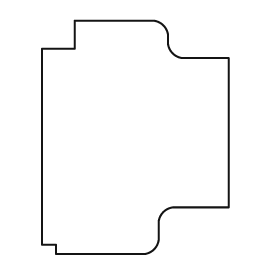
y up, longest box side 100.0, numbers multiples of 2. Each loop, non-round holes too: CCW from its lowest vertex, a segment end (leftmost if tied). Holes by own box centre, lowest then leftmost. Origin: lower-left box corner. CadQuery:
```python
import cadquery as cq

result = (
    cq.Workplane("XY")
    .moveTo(6.0, 0.0)
    .lineTo(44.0, 0.0)
    .threePointArc((48.0, 2.0), (50.0, 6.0))
    .lineTo(50.0, 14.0)
    .threePointArc((52.0, 18.0), (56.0, 20.0))
    .lineTo(80.0, 20.0)
    .lineTo(80.0, 84.0)
    .lineTo(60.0, 84.0)
    .threePointArc((56.0, 86.0), (54.0, 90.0))
    .lineTo(54.0, 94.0)
    .threePointArc((52.0, 98.0), (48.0, 100.0))
    .lineTo(14.0, 100.0)
    .lineTo(14.0, 88.0)
    .lineTo(0.0, 88.0)
    .lineTo(0.0, 4.0)
    .lineTo(6.0, 4.0)
    .close()
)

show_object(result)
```